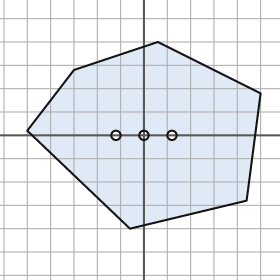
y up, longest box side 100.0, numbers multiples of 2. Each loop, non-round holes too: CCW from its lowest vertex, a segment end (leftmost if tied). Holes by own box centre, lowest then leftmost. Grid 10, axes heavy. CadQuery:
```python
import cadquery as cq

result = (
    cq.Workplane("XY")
    .moveTo(-6.0, -40.0)
    .lineTo(44.0, -28.0)
    .lineTo(50.0, 18.0)
    .lineTo(6.0, 40.0)
    .lineTo(-30.0, 28.0)
    .lineTo(-50.0, 2.0)
    .close()
    .moveTo(-12.0, 0.0)
    .circle(2.0)
    .moveTo(0.0, 0.0)
    .circle(2.0)
    .moveTo(12.0, 0.0)
    .circle(2.0)
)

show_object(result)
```